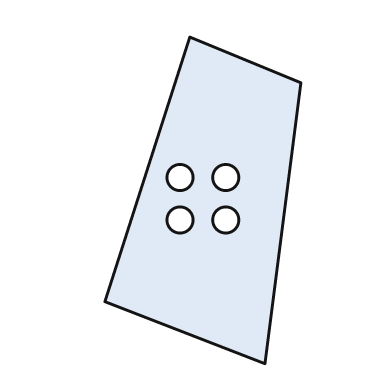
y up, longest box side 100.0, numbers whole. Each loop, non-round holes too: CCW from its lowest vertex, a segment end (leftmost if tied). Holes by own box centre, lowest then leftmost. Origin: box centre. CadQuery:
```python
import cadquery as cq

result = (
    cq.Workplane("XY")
    .moveTo(19.0, -50.0)
    .lineTo(30.0, 36.0)
    .lineTo(-4.0, 50.0)
    .lineTo(-30.0, -31.0)
    .close()
    .moveTo(-7.0, -6.0)
    .circle(4.0)
    .moveTo(7.0, -6.0)
    .circle(4.0)
    .moveTo(-7.0, 7.0)
    .circle(4.0)
    .moveTo(7.0, 7.0)
    .circle(4.0)
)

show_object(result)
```